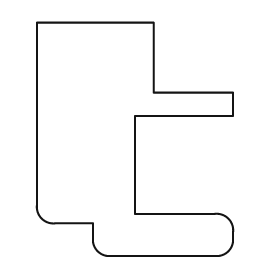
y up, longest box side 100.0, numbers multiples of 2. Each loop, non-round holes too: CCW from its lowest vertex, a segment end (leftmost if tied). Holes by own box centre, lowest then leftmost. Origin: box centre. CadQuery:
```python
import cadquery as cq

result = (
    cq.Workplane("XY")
    .moveTo(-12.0, -50.0)
    .lineTo(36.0, -50.0)
    .threePointArc((40.0, -48.0), (42.0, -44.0))
    .lineTo(42.0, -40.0)
    .threePointArc((40.0, -34.0), (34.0, -32.0))
    .lineTo(0.0, -32.0)
    .lineTo(0.0, 10.0)
    .lineTo(42.0, 10.0)
    .lineTo(42.0, 20.0)
    .lineTo(8.0, 20.0)
    .lineTo(8.0, 50.0)
    .lineTo(-42.0, 50.0)
    .lineTo(-42.0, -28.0)
    .threePointArc((-40.0, -34.0), (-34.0, -36.0))
    .lineTo(-18.0, -36.0)
    .lineTo(-18.0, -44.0)
    .threePointArc((-16.0, -48.0), (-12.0, -50.0))
    .close()
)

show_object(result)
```